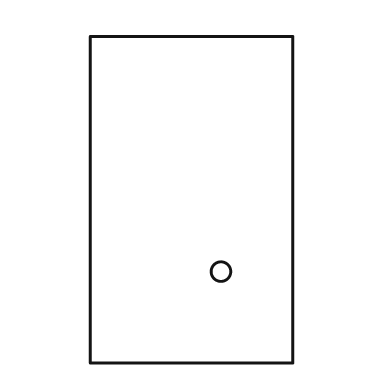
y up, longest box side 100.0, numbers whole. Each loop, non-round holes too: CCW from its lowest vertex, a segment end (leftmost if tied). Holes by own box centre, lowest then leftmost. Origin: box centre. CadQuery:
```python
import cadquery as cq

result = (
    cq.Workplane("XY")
    .moveTo(-31.0, -50.0)
    .lineTo(31.0, -50.0)
    .lineTo(31.0, 50.0)
    .lineTo(-31.0, 50.0)
    .close()
    .moveTo(9.0, -22.0)
    .circle(3.0)
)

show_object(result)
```